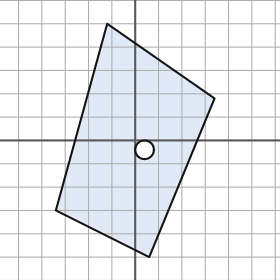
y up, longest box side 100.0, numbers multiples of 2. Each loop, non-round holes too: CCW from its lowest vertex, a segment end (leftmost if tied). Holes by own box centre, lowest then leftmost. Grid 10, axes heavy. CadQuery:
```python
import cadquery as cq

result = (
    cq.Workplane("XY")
    .moveTo(6.0, -50.0)
    .lineTo(34.0, 18.0)
    .lineTo(-12.0, 50.0)
    .lineTo(-34.0, -30.0)
    .close()
    .moveTo(4.0, -4.0)
    .circle(4.0)
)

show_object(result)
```